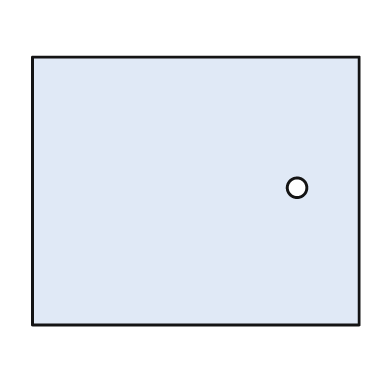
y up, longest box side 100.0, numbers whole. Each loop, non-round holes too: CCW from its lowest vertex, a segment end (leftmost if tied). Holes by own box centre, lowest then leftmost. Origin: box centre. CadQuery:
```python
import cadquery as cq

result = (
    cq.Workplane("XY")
    .moveTo(-50.0, -41.0)
    .lineTo(50.0, -41.0)
    .lineTo(50.0, 41.0)
    .lineTo(-50.0, 41.0)
    .close()
    .moveTo(31.0, 1.0)
    .circle(3.0)
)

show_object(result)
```